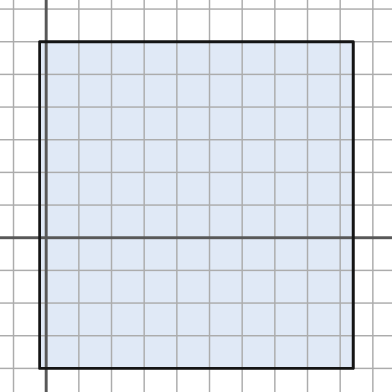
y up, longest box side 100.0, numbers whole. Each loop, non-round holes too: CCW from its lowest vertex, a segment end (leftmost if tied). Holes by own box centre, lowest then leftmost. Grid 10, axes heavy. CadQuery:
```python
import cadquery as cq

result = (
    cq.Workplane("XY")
    .moveTo(-2.0, -40.0)
    .lineTo(94.0, -40.0)
    .lineTo(94.0, 60.0)
    .lineTo(-2.0, 60.0)
    .close()
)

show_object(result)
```